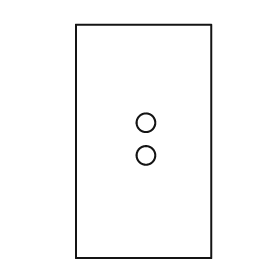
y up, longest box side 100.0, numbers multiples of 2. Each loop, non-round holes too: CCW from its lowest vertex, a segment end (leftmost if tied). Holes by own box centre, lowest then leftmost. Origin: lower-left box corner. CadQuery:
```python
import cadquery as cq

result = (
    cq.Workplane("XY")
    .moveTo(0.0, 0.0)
    .lineTo(58.0, 0.0)
    .lineTo(58.0, 100.0)
    .lineTo(0.0, 100.0)
    .close()
    .moveTo(30.0, 44.0)
    .circle(4.0)
    .moveTo(30.0, 58.0)
    .circle(4.0)
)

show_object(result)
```